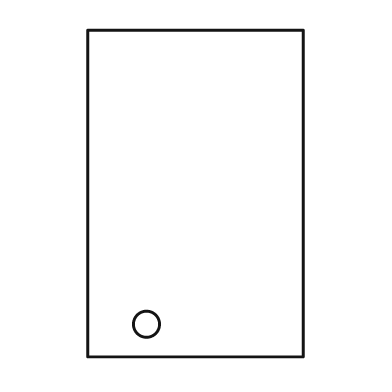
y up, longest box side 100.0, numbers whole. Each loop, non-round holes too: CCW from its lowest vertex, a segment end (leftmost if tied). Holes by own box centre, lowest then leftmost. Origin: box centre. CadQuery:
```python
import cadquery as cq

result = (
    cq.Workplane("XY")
    .moveTo(-33.0, -50.0)
    .lineTo(33.0, -50.0)
    .lineTo(33.0, 50.0)
    .lineTo(-33.0, 50.0)
    .close()
    .moveTo(-15.0, -40.0)
    .circle(4.0)
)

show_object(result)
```